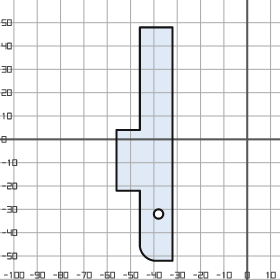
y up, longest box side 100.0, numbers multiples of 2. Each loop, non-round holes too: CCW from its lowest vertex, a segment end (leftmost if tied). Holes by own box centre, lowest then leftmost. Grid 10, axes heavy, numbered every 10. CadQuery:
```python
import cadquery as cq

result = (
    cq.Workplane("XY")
    .moveTo(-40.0, -52.0)
    .lineTo(-32.0, -52.0)
    .lineTo(-32.0, 48.0)
    .lineTo(-46.0, 48.0)
    .lineTo(-46.0, 4.0)
    .lineTo(-56.0, 4.0)
    .lineTo(-56.0, -22.0)
    .lineTo(-46.0, -22.0)
    .lineTo(-46.0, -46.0)
    .threePointArc((-44.0, -50.0), (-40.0, -52.0))
    .close()
    .moveTo(-38.0, -32.0)
    .circle(2.0)
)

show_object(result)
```